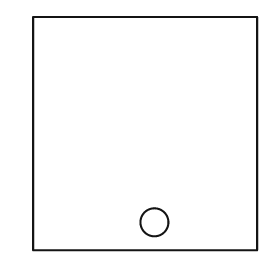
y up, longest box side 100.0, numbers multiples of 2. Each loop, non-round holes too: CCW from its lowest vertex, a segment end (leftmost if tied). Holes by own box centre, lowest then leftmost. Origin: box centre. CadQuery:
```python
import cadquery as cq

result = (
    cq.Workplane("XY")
    .moveTo(-48.0, -50.0)
    .lineTo(48.0, -50.0)
    .lineTo(48.0, 50.0)
    .lineTo(-48.0, 50.0)
    .close()
    .moveTo(4.0, -38.0)
    .circle(6.0)
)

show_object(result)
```